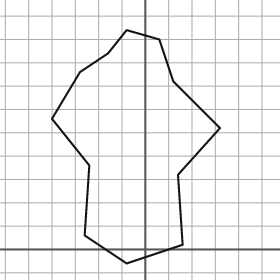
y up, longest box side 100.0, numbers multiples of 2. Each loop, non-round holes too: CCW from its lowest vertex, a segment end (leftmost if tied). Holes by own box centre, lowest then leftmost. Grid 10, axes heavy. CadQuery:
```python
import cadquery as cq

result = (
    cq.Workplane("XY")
    .moveTo(-8.0, -6.0)
    .lineTo(16.0, 2.0)
    .lineTo(14.0, 32.0)
    .lineTo(32.0, 52.0)
    .lineTo(12.0, 72.0)
    .lineTo(6.0, 90.0)
    .lineTo(-8.0, 94.0)
    .lineTo(-16.0, 84.0)
    .lineTo(-28.0, 76.0)
    .lineTo(-40.0, 56.0)
    .lineTo(-24.0, 36.0)
    .lineTo(-26.0, 6.0)
    .close()
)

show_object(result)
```